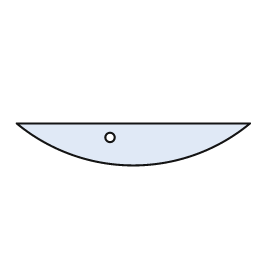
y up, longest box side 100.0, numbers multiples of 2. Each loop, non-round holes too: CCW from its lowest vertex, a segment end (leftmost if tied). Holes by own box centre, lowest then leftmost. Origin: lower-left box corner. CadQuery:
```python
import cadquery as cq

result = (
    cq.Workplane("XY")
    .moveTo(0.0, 18.0)
    .threePointArc((50.0, 0.0), (100.0, 18.0))
    .close()
    .moveTo(40.0, 12.0)
    .circle(2.0)
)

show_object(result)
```